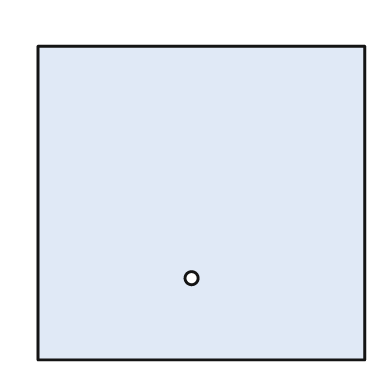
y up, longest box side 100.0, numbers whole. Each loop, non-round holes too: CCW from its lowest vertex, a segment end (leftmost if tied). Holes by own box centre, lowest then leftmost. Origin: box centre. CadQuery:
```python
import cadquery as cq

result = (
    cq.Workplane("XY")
    .moveTo(-50.0, -48.0)
    .lineTo(50.0, -48.0)
    .lineTo(50.0, 48.0)
    .lineTo(-50.0, 48.0)
    .close()
    .moveTo(-3.0, -23.0)
    .circle(2.0)
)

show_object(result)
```